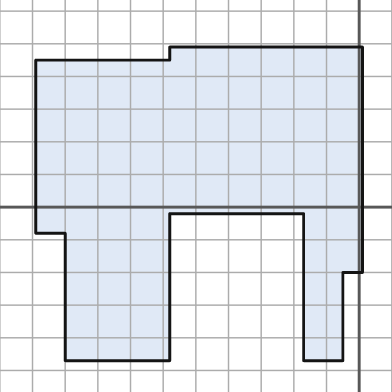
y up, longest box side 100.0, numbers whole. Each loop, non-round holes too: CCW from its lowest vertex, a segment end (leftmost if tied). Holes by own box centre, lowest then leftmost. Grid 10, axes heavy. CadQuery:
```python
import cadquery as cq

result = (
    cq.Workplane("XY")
    .moveTo(-90.0, -47.0)
    .lineTo(-58.0, -47.0)
    .lineTo(-58.0, -2.0)
    .lineTo(-17.0, -2.0)
    .lineTo(-17.0, -47.0)
    .lineTo(-5.0, -47.0)
    .lineTo(-5.0, -20.0)
    .lineTo(1.0, -20.0)
    .lineTo(1.0, 49.0)
    .lineTo(-58.0, 49.0)
    .lineTo(-58.0, 45.0)
    .lineTo(-99.0, 45.0)
    .lineTo(-99.0, -8.0)
    .lineTo(-90.0, -8.0)
    .close()
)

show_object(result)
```